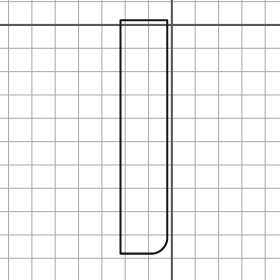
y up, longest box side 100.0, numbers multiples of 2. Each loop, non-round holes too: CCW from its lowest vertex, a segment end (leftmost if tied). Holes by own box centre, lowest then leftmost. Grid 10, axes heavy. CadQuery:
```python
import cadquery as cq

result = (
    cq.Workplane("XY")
    .moveTo(-22.0, -98.0)
    .lineTo(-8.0, -98.0)
    .threePointArc((-4.0, -96.0), (-2.0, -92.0))
    .lineTo(-2.0, 2.0)
    .lineTo(-22.0, 2.0)
    .close()
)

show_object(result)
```